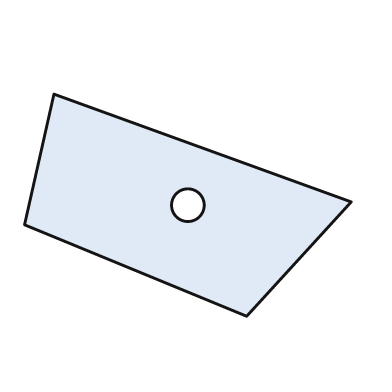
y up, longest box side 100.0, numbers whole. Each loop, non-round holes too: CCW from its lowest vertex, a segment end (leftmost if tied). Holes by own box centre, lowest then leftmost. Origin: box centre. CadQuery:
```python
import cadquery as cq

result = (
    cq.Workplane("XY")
    .moveTo(18.0, -34.0)
    .lineTo(50.0, 1.0)
    .lineTo(-41.0, 34.0)
    .lineTo(-50.0, -6.0)
    .close()
    .moveTo(0.0, 0.0)
    .circle(5.0)
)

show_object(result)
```